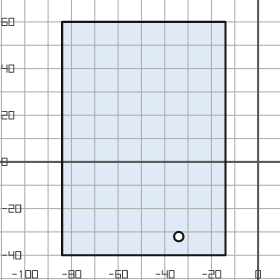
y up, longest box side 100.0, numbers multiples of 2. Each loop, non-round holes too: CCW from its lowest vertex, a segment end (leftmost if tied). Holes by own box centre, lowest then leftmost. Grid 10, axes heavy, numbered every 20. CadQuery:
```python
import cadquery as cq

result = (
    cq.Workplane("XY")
    .moveTo(-84.0, -40.0)
    .lineTo(-14.0, -40.0)
    .lineTo(-14.0, 60.0)
    .lineTo(-84.0, 60.0)
    .close()
    .moveTo(-34.0, -32.0)
    .circle(2.0)
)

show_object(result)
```